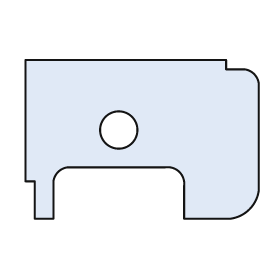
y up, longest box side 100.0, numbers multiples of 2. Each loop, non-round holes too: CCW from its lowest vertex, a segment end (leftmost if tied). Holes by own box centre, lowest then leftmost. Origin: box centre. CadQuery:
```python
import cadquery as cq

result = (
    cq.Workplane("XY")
    .moveTo(-46.0, -34.0)
    .lineTo(-38.0, -34.0)
    .lineTo(-38.0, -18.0)
    .threePointArc((-36.0, -14.0), (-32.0, -12.0))
    .lineTo(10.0, -12.0)
    .threePointArc((16.0, -14.0), (18.0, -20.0))
    .lineTo(18.0, -34.0)
    .lineTo(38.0, -34.0)
    .threePointArc((46.0, -30.0), (50.0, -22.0))
    .lineTo(50.0, 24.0)
    .threePointArc((48.0, 28.0), (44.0, 30.0))
    .lineTo(36.0, 30.0)
    .lineTo(36.0, 34.0)
    .lineTo(-50.0, 34.0)
    .lineTo(-50.0, -18.0)
    .lineTo(-46.0, -18.0)
    .close()
    .moveTo(-10.0, 4.0)
    .circle(8.0)
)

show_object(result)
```